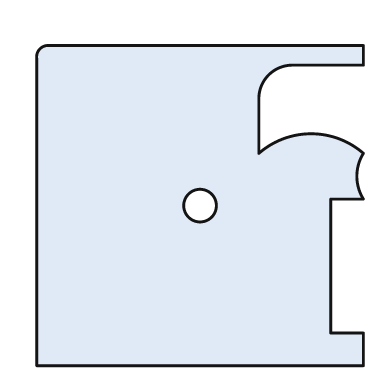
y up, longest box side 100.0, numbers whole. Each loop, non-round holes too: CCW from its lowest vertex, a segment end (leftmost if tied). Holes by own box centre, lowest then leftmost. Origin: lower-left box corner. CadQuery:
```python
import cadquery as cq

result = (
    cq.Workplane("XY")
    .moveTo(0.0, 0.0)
    .lineTo(100.0, 0.0)
    .lineTo(100.0, 10.0)
    .lineTo(90.0, 10.0)
    .lineTo(90.0, 51.0)
    .lineTo(100.0, 51.0)
    .threePointArc((98.0, 58.0), (100.0, 65.0))
    .threePointArc((84.0, 71.0), (68.0, 65.0))
    .lineTo(68.0, 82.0)
    .threePointArc((71.0, 89.0), (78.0, 92.0))
    .lineTo(100.0, 92.0)
    .lineTo(100.0, 98.0)
    .lineTo(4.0, 98.0)
    .threePointArc((1.0, 97.0), (0.0, 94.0))
    .close()
    .moveTo(50.0, 49.0)
    .circle(5.0)
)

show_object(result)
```